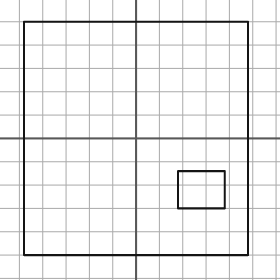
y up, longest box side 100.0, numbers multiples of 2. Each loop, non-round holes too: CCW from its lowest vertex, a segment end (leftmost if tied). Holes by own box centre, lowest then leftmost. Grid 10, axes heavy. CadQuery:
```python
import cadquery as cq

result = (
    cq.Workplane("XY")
    .moveTo(-48.0, -50.0)
    .lineTo(48.0, -50.0)
    .lineTo(48.0, 50.0)
    .lineTo(-48.0, 50.0)
    .close()
    .moveTo(18.0, -30.0)
    .lineTo(38.0, -30.0)
    .lineTo(38.0, -14.0)
    .lineTo(18.0, -14.0)
    .close()
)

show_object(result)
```